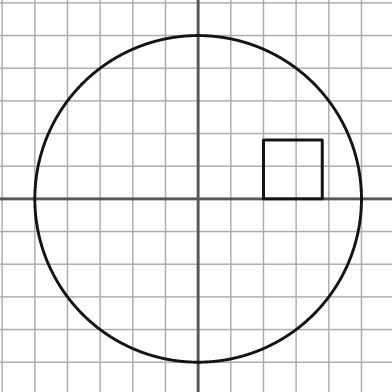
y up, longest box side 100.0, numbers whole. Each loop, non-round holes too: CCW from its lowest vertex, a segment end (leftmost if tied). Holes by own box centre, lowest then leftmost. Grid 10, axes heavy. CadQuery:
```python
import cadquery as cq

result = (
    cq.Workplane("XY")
    .moveTo(0.0, 0.0)
    .circle(50.0)
    .moveTo(20.0, 0.0)
    .lineTo(38.0, 0.0)
    .lineTo(38.0, 18.0)
    .lineTo(20.0, 18.0)
    .close()
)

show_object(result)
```